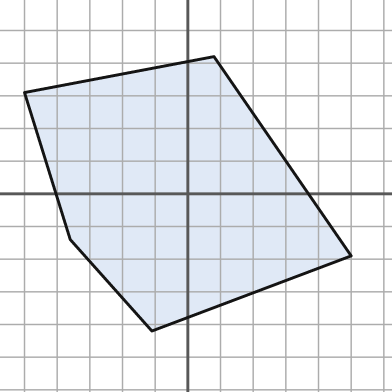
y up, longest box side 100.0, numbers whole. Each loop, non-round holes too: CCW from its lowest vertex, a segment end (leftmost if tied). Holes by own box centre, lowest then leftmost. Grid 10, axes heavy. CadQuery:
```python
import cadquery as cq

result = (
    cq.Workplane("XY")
    .moveTo(-11.0, -42.0)
    .lineTo(50.0, -19.0)
    .lineTo(8.0, 42.0)
    .lineTo(-50.0, 31.0)
    .lineTo(-36.0, -14.0)
    .close()
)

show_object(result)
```